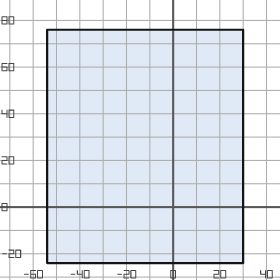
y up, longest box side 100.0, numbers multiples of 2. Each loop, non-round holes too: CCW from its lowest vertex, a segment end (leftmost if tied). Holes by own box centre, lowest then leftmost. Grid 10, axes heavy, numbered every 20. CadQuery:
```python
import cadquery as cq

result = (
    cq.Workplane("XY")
    .moveTo(-54.0, -24.0)
    .lineTo(30.0, -24.0)
    .lineTo(30.0, 76.0)
    .lineTo(-54.0, 76.0)
    .close()
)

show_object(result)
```